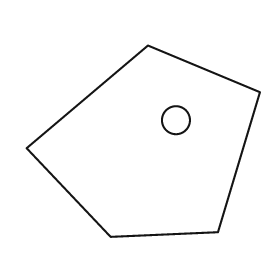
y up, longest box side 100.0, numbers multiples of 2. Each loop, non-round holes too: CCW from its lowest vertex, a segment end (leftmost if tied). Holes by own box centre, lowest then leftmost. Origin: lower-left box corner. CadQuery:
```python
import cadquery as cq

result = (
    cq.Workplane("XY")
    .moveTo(36.0, 0.0)
    .lineTo(82.0, 2.0)
    .lineTo(100.0, 62.0)
    .lineTo(52.0, 82.0)
    .lineTo(0.0, 38.0)
    .close()
    .moveTo(64.0, 50.0)
    .circle(6.0)
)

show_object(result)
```